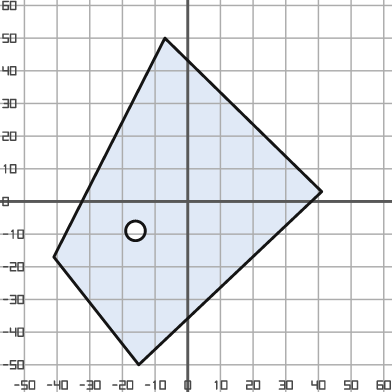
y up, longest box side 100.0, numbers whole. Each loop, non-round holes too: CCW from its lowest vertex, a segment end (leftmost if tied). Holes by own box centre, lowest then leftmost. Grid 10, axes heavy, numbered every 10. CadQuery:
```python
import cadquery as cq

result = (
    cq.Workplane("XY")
    .moveTo(-15.0, -50.0)
    .lineTo(41.0, 3.0)
    .lineTo(-7.0, 50.0)
    .lineTo(-41.0, -17.0)
    .close()
    .moveTo(-16.0, -9.0)
    .circle(3.0)
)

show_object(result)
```